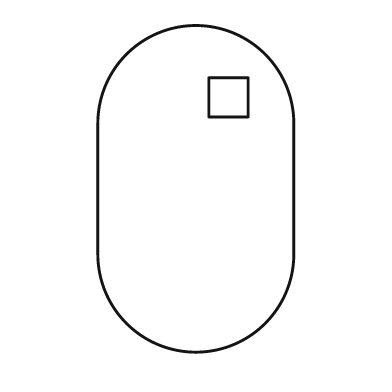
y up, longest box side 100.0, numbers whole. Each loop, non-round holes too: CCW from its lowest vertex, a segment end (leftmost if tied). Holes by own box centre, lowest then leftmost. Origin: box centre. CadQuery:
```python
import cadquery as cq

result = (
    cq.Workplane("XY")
    .moveTo(-30.0, -20.0)
    .threePointArc((0.0, -50.0), (30.0, -20.0))
    .lineTo(30.0, 20.0)
    .threePointArc((0.0, 50.0), (-30.0, 20.0))
    .close()
    .moveTo(4.0, 22.0)
    .lineTo(16.0, 22.0)
    .lineTo(16.0, 34.0)
    .lineTo(4.0, 34.0)
    .close()
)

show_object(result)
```